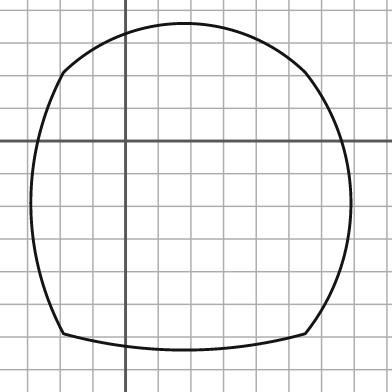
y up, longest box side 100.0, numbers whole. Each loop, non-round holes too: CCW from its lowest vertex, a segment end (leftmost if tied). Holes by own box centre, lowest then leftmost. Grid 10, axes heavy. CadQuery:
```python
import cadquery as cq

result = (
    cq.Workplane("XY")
    .moveTo(-19.0, -59.0)
    .threePointArc((18.0, -64.0), (55.0, -59.0))
    .threePointArc((69.0, -19.0), (55.0, 21.0))
    .threePointArc((18.0, 36.0), (-19.0, 21.0))
    .threePointArc((-29.0, -19.0), (-19.0, -59.0))
    .close()
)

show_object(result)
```